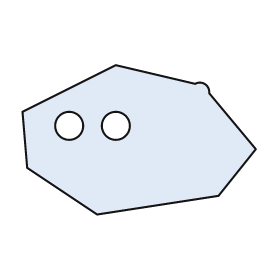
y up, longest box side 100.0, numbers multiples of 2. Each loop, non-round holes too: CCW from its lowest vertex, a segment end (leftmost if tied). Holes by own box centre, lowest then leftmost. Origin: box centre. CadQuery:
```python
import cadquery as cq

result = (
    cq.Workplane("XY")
    .moveTo(-18.0, -32.0)
    .lineTo(34.0, -24.0)
    .lineTo(50.0, -4.0)
    .lineTo(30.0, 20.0)
    .threePointArc((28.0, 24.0), (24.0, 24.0))
    .lineTo(-10.0, 32.0)
    .lineTo(-50.0, 12.0)
    .lineTo(-48.0, -12.0)
    .close()
    .moveTo(-30.0, 6.0)
    .circle(6.0)
    .moveTo(-10.0, 6.0)
    .circle(6.0)
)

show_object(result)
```